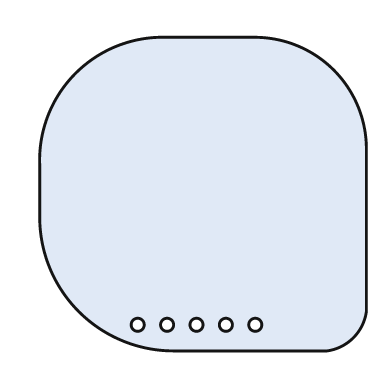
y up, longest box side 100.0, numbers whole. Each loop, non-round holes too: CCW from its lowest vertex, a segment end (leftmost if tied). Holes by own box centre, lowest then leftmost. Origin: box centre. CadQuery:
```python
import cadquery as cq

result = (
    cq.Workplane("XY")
    .moveTo(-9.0, -48.0)
    .lineTo(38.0, -48.0)
    .threePointArc((46.0, -44.0), (50.0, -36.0))
    .lineTo(50.0, 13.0)
    .threePointArc((40.0, 38.0), (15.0, 48.0))
    .lineTo(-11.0, 48.0)
    .threePointArc((-39.0, 37.0), (-50.0, 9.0))
    .lineTo(-50.0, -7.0)
    .threePointArc((-38.0, -36.0), (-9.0, -48.0))
    .close()
    .moveTo(-20.0, -40.0)
    .circle(2.0)
    .moveTo(-11.0, -40.0)
    .circle(2.0)
    .moveTo(-2.0, -40.0)
    .circle(2.0)
    .moveTo(7.0, -40.0)
    .circle(2.0)
    .moveTo(16.0, -40.0)
    .circle(2.0)
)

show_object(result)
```